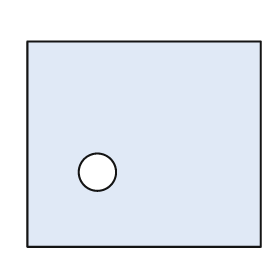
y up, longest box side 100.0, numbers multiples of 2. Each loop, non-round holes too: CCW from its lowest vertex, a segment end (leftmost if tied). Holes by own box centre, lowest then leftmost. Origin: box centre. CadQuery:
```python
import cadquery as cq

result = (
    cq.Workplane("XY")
    .moveTo(-50.0, -44.0)
    .lineTo(50.0, -44.0)
    .lineTo(50.0, 44.0)
    .lineTo(-50.0, 44.0)
    .close()
    .moveTo(-20.0, -12.0)
    .circle(8.0)
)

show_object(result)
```